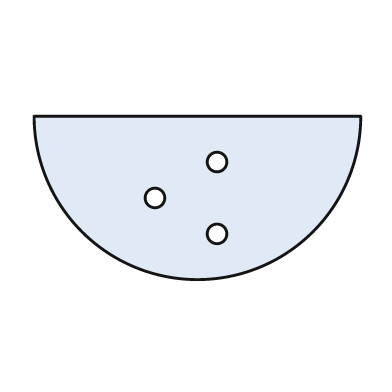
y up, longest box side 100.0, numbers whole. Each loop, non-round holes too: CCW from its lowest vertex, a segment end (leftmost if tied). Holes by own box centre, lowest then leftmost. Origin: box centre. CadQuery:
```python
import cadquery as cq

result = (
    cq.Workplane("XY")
    .moveTo(-50.0, 25.0)
    .threePointArc((0.0, -25.0), (50.0, 25.0))
    .close()
    .moveTo(6.0, -11.0)
    .circle(3.0)
    .moveTo(-13.0, 0.0)
    .circle(3.0)
    .moveTo(6.0, 11.0)
    .circle(3.0)
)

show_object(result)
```